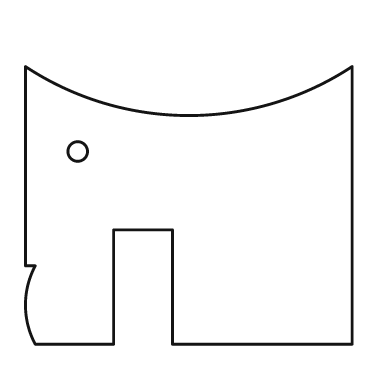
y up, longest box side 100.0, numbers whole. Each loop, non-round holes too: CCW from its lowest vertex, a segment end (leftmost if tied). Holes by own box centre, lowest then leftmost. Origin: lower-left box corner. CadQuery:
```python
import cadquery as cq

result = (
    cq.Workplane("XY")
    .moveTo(3.0, 0.0)
    .lineTo(27.0, 0.0)
    .lineTo(27.0, 35.0)
    .lineTo(45.0, 35.0)
    .lineTo(45.0, 0.0)
    .lineTo(100.0, 0.0)
    .lineTo(100.0, 85.0)
    .threePointArc((50.0, 70.0), (0.0, 85.0))
    .lineTo(0.0, 24.0)
    .lineTo(3.0, 24.0)
    .threePointArc((0.0, 12.0), (3.0, 0.0))
    .close()
    .moveTo(16.0, 59.0)
    .circle(3.0)
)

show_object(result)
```